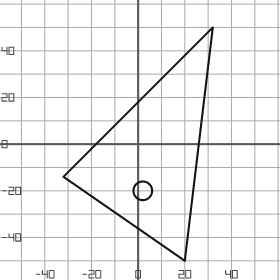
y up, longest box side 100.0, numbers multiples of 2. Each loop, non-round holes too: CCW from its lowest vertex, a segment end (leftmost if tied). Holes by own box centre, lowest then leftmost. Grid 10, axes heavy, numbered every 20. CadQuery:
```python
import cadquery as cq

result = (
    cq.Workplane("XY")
    .moveTo(20.0, -50.0)
    .lineTo(32.0, 50.0)
    .lineTo(-32.0, -14.0)
    .close()
    .moveTo(2.0, -20.0)
    .circle(4.0)
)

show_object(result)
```